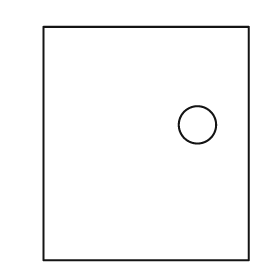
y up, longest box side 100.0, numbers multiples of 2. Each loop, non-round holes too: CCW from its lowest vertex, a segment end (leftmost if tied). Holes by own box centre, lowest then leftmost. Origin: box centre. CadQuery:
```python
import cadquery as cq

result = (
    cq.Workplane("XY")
    .moveTo(-44.0, -50.0)
    .lineTo(44.0, -50.0)
    .lineTo(44.0, 50.0)
    .lineTo(-44.0, 50.0)
    .close()
    .moveTo(22.0, 8.0)
    .circle(8.0)
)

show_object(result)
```